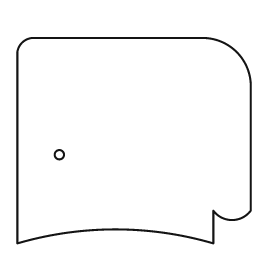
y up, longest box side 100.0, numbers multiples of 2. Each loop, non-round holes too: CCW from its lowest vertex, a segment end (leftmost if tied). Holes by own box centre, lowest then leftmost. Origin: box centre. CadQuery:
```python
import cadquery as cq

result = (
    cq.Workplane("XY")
    .moveTo(-50.0, -44.0)
    .threePointArc((-8.0, -38.0), (34.0, -44.0))
    .lineTo(34.0, -30.0)
    .threePointArc((42.0, -34.0), (50.0, -30.0))
    .lineTo(50.0, 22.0)
    .threePointArc((44.0, 38.0), (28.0, 44.0))
    .lineTo(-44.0, 44.0)
    .threePointArc((-48.0, 42.0), (-50.0, 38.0))
    .close()
    .moveTo(-32.0, -6.0)
    .circle(2.0)
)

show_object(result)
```